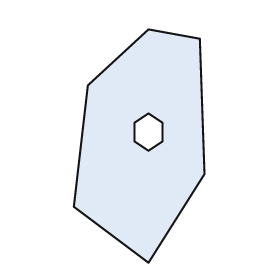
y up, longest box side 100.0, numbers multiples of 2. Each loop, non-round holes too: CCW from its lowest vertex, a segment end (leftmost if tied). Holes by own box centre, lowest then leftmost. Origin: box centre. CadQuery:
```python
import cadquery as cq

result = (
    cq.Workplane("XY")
    .moveTo(4.0, -50.0)
    .lineTo(28.0, -12.0)
    .lineTo(26.0, 46.0)
    .lineTo(4.0, 50.0)
    .lineTo(-22.0, 26.0)
    .lineTo(-28.0, -26.0)
    .close()
    .moveTo(4.0, -2.0)
    .lineTo(10.0, 2.0)
    .lineTo(10.0, 10.0)
    .lineTo(4.0, 14.0)
    .lineTo(-2.0, 10.0)
    .lineTo(-2.0, 2.0)
    .close()
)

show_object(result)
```